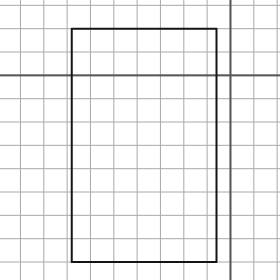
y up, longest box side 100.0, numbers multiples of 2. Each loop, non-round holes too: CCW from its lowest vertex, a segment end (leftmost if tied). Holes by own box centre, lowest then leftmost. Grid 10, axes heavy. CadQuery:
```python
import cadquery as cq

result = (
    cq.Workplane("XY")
    .moveTo(-68.0, -80.0)
    .lineTo(-6.0, -80.0)
    .lineTo(-6.0, 20.0)
    .lineTo(-68.0, 20.0)
    .close()
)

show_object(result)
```